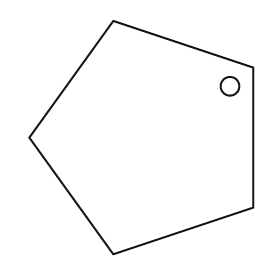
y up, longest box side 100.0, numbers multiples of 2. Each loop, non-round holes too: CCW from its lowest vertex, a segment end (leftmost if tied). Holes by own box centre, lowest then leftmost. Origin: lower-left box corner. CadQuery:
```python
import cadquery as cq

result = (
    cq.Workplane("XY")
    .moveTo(36.0, 0.0)
    .lineTo(96.0, 20.0)
    .lineTo(96.0, 80.0)
    .lineTo(36.0, 100.0)
    .lineTo(0.0, 50.0)
    .close()
    .moveTo(86.0, 72.0)
    .circle(4.0)
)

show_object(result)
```